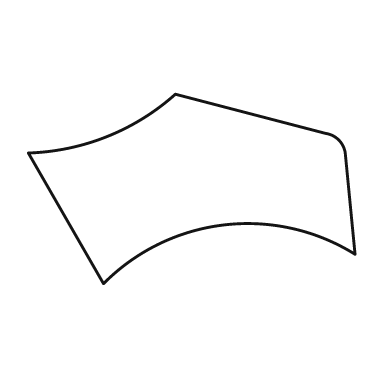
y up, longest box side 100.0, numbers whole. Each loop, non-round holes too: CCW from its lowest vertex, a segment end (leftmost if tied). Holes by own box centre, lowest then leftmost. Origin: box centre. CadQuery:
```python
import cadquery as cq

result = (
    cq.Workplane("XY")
    .moveTo(-27.0, -29.0)
    .threePointArc((10.0, -11.0), (50.0, -20.0))
    .lineTo(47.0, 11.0)
    .threePointArc((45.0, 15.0), (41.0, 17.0))
    .lineTo(-5.0, 29.0)
    .threePointArc((-26.0, 16.0), (-50.0, 11.0))
    .close()
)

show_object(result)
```